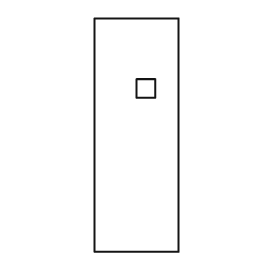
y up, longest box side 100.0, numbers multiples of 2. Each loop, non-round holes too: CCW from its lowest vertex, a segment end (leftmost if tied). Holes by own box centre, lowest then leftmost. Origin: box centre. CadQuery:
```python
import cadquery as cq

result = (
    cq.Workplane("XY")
    .moveTo(-18.0, -50.0)
    .lineTo(18.0, -50.0)
    .lineTo(18.0, 50.0)
    .lineTo(-18.0, 50.0)
    .close()
    .moveTo(0.0, 16.0)
    .lineTo(8.0, 16.0)
    .lineTo(8.0, 24.0)
    .lineTo(0.0, 24.0)
    .close()
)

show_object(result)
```